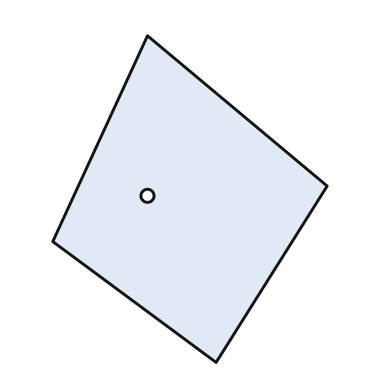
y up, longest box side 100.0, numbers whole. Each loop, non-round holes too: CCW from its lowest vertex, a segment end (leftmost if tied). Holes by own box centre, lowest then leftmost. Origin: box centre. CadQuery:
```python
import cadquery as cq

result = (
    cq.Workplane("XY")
    .moveTo(8.0, -50.0)
    .lineTo(42.0, 4.0)
    .lineTo(-13.0, 50.0)
    .lineTo(-42.0, -13.0)
    .close()
    .moveTo(-13.0, 1.0)
    .circle(2.0)
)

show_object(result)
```